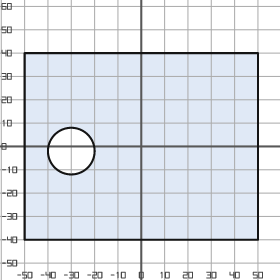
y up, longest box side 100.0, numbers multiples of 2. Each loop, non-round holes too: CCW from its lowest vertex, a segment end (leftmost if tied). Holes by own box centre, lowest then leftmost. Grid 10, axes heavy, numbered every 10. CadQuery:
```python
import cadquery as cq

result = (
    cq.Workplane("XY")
    .moveTo(-50.0, -40.0)
    .lineTo(50.0, -40.0)
    .lineTo(50.0, 40.0)
    .lineTo(-50.0, 40.0)
    .close()
    .moveTo(-30.0, -2.0)
    .circle(10.0)
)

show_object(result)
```